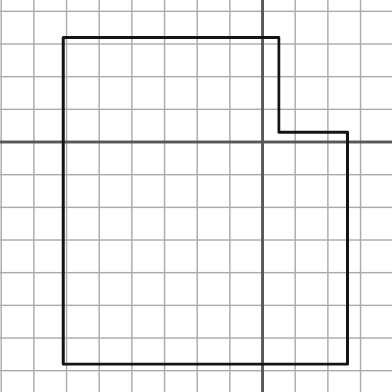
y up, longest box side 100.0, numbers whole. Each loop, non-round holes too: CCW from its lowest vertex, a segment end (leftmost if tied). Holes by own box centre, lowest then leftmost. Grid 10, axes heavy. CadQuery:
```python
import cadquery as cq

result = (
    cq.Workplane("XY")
    .moveTo(-61.0, -68.0)
    .lineTo(26.0, -68.0)
    .lineTo(26.0, 3.0)
    .lineTo(5.0, 3.0)
    .lineTo(5.0, 32.0)
    .lineTo(-61.0, 32.0)
    .close()
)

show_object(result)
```